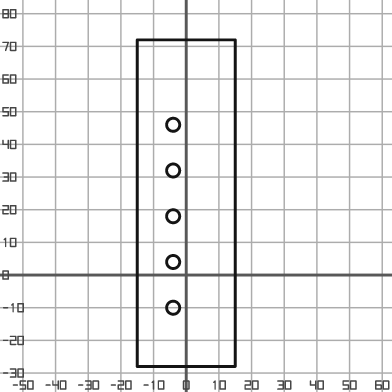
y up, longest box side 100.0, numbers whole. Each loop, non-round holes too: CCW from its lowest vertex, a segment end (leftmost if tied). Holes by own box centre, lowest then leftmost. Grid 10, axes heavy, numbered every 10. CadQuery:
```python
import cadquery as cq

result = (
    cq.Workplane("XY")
    .moveTo(-15.0, -28.0)
    .lineTo(15.0, -28.0)
    .lineTo(15.0, 72.0)
    .lineTo(-15.0, 72.0)
    .close()
    .moveTo(-4.0, -10.0)
    .circle(2.0)
    .moveTo(-4.0, 4.0)
    .circle(2.0)
    .moveTo(-4.0, 18.0)
    .circle(2.0)
    .moveTo(-4.0, 32.0)
    .circle(2.0)
    .moveTo(-4.0, 46.0)
    .circle(2.0)
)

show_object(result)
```